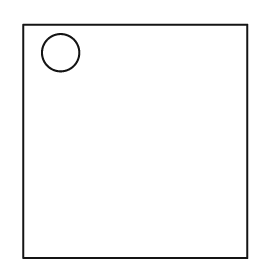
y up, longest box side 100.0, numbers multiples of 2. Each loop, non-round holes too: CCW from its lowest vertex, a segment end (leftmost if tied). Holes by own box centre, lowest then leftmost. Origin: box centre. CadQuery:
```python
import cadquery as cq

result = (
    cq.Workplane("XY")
    .moveTo(-48.0, -50.0)
    .lineTo(48.0, -50.0)
    .lineTo(48.0, 50.0)
    .lineTo(-48.0, 50.0)
    .close()
    .moveTo(-32.0, 38.0)
    .circle(8.0)
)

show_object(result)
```